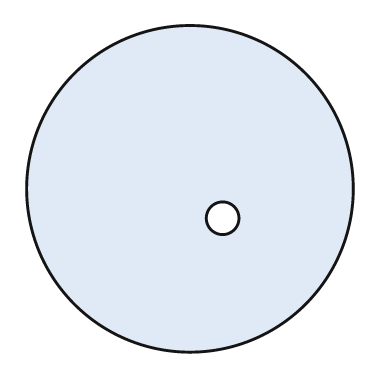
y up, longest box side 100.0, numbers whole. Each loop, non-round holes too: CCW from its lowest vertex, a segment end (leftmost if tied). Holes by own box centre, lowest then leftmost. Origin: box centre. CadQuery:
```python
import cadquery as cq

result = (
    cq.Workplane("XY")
    .moveTo(0.0, 0.0)
    .circle(50.0)
    .moveTo(10.0, -9.0)
    .circle(5.0)
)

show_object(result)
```